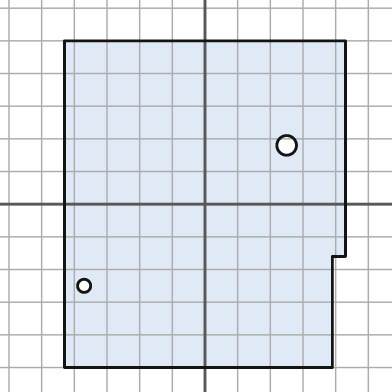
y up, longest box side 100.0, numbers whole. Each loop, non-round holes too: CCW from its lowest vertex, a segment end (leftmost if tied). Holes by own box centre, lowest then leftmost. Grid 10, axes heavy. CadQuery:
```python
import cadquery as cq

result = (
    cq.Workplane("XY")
    .moveTo(-43.0, -50.0)
    .lineTo(39.0, -50.0)
    .lineTo(39.0, -16.0)
    .lineTo(43.0, -16.0)
    .lineTo(43.0, 50.0)
    .lineTo(-43.0, 50.0)
    .close()
    .moveTo(-37.0, -25.0)
    .circle(2.0)
    .moveTo(25.0, 18.0)
    .circle(3.0)
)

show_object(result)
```